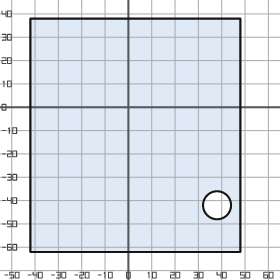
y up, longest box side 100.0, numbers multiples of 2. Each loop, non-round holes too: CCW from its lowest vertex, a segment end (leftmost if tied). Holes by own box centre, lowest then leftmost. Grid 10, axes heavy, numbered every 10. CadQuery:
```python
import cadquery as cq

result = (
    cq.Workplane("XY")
    .moveTo(-42.0, -62.0)
    .lineTo(48.0, -62.0)
    .lineTo(48.0, 38.0)
    .lineTo(-42.0, 38.0)
    .close()
    .moveTo(38.0, -42.0)
    .circle(6.0)
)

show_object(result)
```